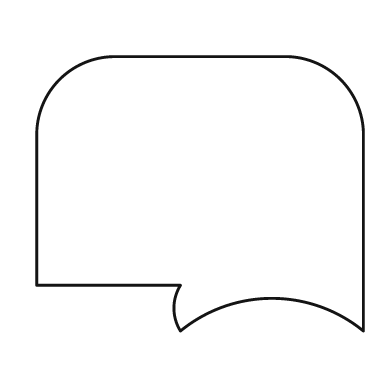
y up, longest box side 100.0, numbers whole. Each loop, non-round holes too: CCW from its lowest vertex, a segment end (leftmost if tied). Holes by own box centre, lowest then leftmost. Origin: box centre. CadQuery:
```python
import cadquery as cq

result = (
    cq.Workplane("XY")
    .moveTo(-6.0, -42.0)
    .threePointArc((22.0, -32.0), (50.0, -42.0))
    .lineTo(50.0, 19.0)
    .threePointArc((43.0, 35.0), (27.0, 42.0))
    .lineTo(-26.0, 42.0)
    .threePointArc((-43.0, 35.0), (-50.0, 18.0))
    .lineTo(-50.0, -28.0)
    .lineTo(-6.0, -28.0)
    .threePointArc((-8.0, -35.0), (-6.0, -42.0))
    .close()
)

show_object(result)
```